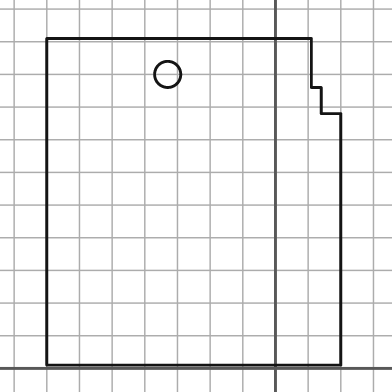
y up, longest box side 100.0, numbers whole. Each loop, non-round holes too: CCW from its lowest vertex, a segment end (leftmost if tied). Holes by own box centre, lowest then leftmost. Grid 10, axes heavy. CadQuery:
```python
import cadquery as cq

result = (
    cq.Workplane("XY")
    .moveTo(-70.0, 1.0)
    .lineTo(20.0, 1.0)
    .lineTo(20.0, 78.0)
    .lineTo(14.0, 78.0)
    .lineTo(14.0, 86.0)
    .lineTo(11.0, 86.0)
    .lineTo(11.0, 101.0)
    .lineTo(-70.0, 101.0)
    .close()
    .moveTo(-33.0, 90.0)
    .circle(4.0)
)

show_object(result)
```